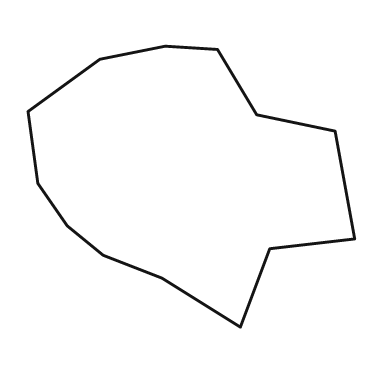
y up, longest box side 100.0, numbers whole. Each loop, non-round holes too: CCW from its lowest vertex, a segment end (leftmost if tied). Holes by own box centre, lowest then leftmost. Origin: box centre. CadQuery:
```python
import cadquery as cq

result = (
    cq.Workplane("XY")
    .moveTo(15.0, -43.0)
    .lineTo(24.0, -19.0)
    .lineTo(50.0, -16.0)
    .lineTo(44.0, 17.0)
    .lineTo(20.0, 22.0)
    .lineTo(8.0, 42.0)
    .lineTo(-8.0, 43.0)
    .lineTo(-28.0, 39.0)
    .lineTo(-50.0, 23.0)
    .lineTo(-47.0, 1.0)
    .lineTo(-38.0, -12.0)
    .lineTo(-27.0, -21.0)
    .lineTo(-9.0, -28.0)
    .close()
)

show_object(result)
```